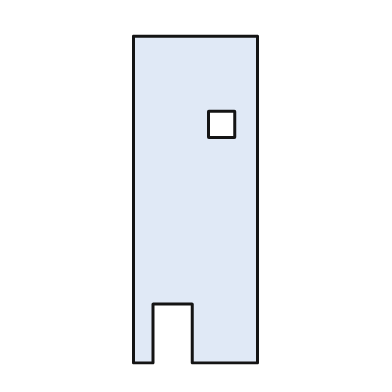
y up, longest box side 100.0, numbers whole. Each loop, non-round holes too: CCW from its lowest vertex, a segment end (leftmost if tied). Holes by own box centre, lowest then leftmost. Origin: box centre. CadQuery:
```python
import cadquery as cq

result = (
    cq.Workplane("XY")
    .moveTo(-19.0, -50.0)
    .lineTo(-13.0, -50.0)
    .lineTo(-13.0, -32.0)
    .lineTo(-1.0, -32.0)
    .lineTo(-1.0, -50.0)
    .lineTo(19.0, -50.0)
    .lineTo(19.0, 50.0)
    .lineTo(-19.0, 50.0)
    .close()
    .moveTo(4.0, 19.0)
    .lineTo(12.0, 19.0)
    .lineTo(12.0, 27.0)
    .lineTo(4.0, 27.0)
    .close()
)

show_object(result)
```